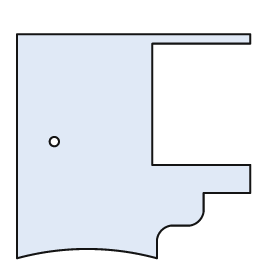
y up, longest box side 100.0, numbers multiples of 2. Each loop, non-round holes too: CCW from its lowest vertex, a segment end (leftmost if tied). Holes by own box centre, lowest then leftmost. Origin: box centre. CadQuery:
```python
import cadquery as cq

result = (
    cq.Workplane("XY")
    .moveTo(-50.0, -48.0)
    .threePointArc((-20.0, -44.0), (10.0, -48.0))
    .lineTo(10.0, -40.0)
    .threePointArc((12.0, -36.0), (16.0, -34.0))
    .lineTo(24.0, -34.0)
    .threePointArc((28.0, -32.0), (30.0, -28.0))
    .lineTo(30.0, -20.0)
    .lineTo(50.0, -20.0)
    .lineTo(50.0, -8.0)
    .lineTo(8.0, -8.0)
    .lineTo(8.0, 44.0)
    .lineTo(50.0, 44.0)
    .lineTo(50.0, 48.0)
    .lineTo(-50.0, 48.0)
    .close()
    .moveTo(-34.0, 2.0)
    .circle(2.0)
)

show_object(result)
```